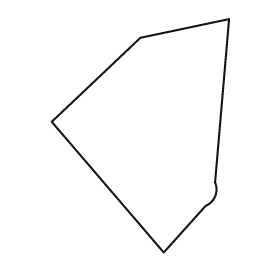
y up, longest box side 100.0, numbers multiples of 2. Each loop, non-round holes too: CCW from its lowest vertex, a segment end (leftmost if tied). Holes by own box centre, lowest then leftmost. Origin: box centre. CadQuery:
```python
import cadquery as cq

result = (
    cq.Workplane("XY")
    .moveTo(10.0, -50.0)
    .lineTo(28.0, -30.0)
    .threePointArc((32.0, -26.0), (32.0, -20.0))
    .lineTo(38.0, 50.0)
    .lineTo(0.0, 42.0)
    .lineTo(-38.0, 6.0)
    .close()
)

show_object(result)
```